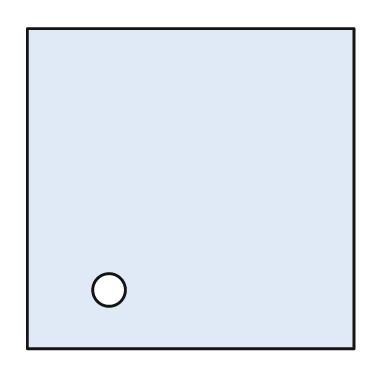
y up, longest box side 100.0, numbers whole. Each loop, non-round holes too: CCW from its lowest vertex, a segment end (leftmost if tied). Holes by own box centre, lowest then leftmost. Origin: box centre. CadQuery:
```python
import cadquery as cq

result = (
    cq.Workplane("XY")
    .moveTo(-50.0, -49.0)
    .lineTo(50.0, -49.0)
    .lineTo(50.0, 49.0)
    .lineTo(-50.0, 49.0)
    .close()
    .moveTo(-25.0, -31.0)
    .circle(5.0)
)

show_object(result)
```